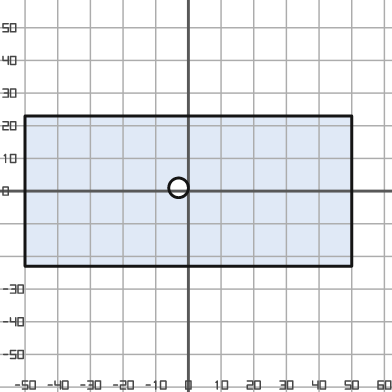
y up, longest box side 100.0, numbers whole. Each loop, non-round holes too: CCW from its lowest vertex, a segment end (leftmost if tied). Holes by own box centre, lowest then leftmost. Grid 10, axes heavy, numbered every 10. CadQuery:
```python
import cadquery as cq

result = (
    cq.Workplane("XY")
    .moveTo(-50.0, -23.0)
    .lineTo(50.0, -23.0)
    .lineTo(50.0, 23.0)
    .lineTo(-50.0, 23.0)
    .close()
    .moveTo(-3.0, 1.0)
    .circle(3.0)
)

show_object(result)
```